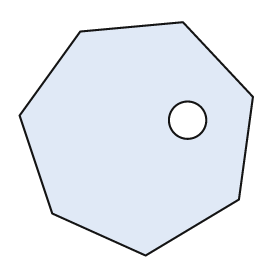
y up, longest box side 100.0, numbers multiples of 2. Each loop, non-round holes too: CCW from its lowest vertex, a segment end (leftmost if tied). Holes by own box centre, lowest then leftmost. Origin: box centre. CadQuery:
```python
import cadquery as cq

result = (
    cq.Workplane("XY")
    .moveTo(4.0, -50.0)
    .lineTo(44.0, -26.0)
    .lineTo(50.0, 18.0)
    .lineTo(20.0, 50.0)
    .lineTo(-24.0, 46.0)
    .lineTo(-50.0, 10.0)
    .lineTo(-36.0, -32.0)
    .close()
    .moveTo(22.0, 8.0)
    .circle(8.0)
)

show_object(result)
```